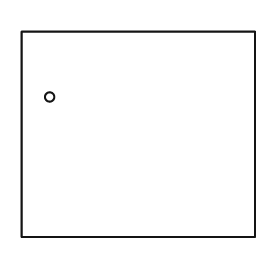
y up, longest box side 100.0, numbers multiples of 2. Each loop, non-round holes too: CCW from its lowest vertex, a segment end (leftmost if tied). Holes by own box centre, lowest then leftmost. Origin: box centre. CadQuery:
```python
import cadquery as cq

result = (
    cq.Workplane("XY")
    .moveTo(-50.0, -44.0)
    .lineTo(50.0, -44.0)
    .lineTo(50.0, 44.0)
    .lineTo(-50.0, 44.0)
    .close()
    .moveTo(-38.0, 16.0)
    .circle(2.0)
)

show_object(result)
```